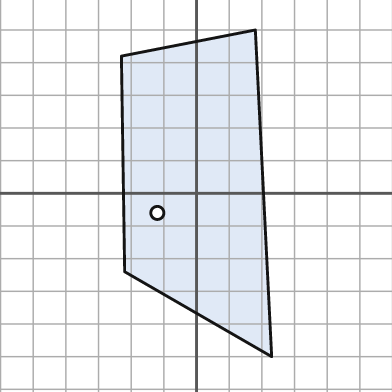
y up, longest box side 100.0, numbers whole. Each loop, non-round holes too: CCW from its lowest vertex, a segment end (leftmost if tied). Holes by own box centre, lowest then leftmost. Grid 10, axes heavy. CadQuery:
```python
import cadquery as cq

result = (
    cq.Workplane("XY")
    .moveTo(23.0, -50.0)
    .lineTo(18.0, 50.0)
    .lineTo(-23.0, 42.0)
    .lineTo(-22.0, -24.0)
    .close()
    .moveTo(-12.0, -6.0)
    .circle(2.0)
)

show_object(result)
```